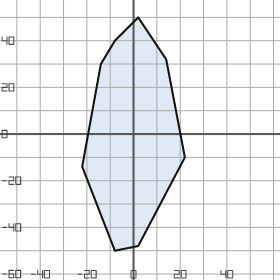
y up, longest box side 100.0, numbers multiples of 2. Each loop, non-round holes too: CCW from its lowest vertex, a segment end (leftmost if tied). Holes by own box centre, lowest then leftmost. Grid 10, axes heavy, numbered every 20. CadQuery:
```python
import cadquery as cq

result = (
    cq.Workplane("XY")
    .moveTo(-8.0, -50.0)
    .lineTo(2.0, -48.0)
    .lineTo(22.0, -10.0)
    .lineTo(14.0, 32.0)
    .lineTo(2.0, 50.0)
    .lineTo(-8.0, 40.0)
    .lineTo(-14.0, 30.0)
    .lineTo(-22.0, -14.0)
    .close()
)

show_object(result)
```